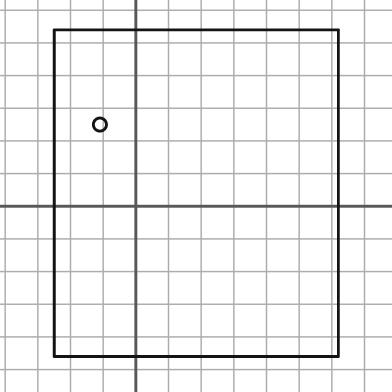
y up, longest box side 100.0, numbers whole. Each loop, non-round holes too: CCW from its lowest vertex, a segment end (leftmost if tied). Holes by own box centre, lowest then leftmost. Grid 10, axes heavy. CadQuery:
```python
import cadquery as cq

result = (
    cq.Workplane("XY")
    .moveTo(-25.0, -46.0)
    .lineTo(62.0, -46.0)
    .lineTo(62.0, 54.0)
    .lineTo(-25.0, 54.0)
    .close()
    .moveTo(-11.0, 25.0)
    .circle(2.0)
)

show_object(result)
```